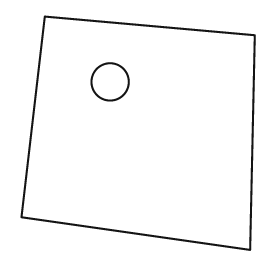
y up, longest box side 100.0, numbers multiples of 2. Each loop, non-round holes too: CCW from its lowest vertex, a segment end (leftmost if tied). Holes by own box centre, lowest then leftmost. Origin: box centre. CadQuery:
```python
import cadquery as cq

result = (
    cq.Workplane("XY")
    .moveTo(48.0, -50.0)
    .lineTo(50.0, 42.0)
    .lineTo(-40.0, 50.0)
    .lineTo(-50.0, -36.0)
    .close()
    .moveTo(-12.0, 22.0)
    .circle(8.0)
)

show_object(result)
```